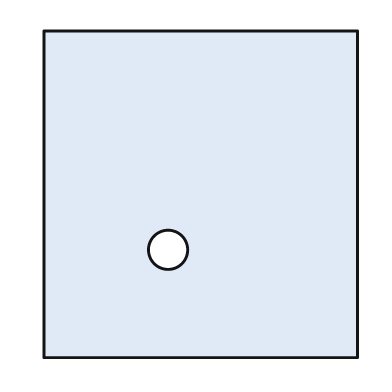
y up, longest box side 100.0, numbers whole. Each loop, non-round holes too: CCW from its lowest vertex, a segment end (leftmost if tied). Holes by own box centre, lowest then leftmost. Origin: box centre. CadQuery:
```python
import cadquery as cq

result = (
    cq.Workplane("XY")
    .moveTo(-48.0, -50.0)
    .lineTo(48.0, -50.0)
    .lineTo(48.0, 50.0)
    .lineTo(-48.0, 50.0)
    .close()
    .moveTo(-10.0, -17.0)
    .circle(6.0)
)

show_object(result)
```